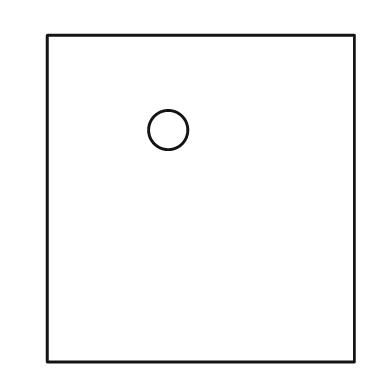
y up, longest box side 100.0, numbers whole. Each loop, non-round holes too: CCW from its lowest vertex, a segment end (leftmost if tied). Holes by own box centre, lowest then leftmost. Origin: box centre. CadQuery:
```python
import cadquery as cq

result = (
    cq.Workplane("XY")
    .moveTo(-47.0, -50.0)
    .lineTo(47.0, -50.0)
    .lineTo(47.0, 50.0)
    .lineTo(-47.0, 50.0)
    .close()
    .moveTo(-10.0, 21.0)
    .circle(6.0)
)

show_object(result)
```